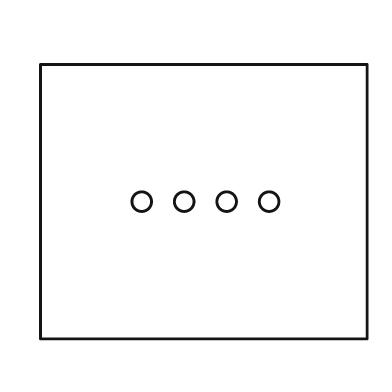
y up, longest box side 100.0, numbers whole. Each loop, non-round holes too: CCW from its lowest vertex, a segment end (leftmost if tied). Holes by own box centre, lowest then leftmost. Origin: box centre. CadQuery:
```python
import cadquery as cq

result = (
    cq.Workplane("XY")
    .moveTo(-50.0, -42.0)
    .lineTo(50.0, -42.0)
    .lineTo(50.0, 42.0)
    .lineTo(-50.0, 42.0)
    .close()
    .moveTo(-19.0, 0.0)
    .circle(3.0)
    .moveTo(-6.0, 0.0)
    .circle(3.0)
    .moveTo(7.0, 0.0)
    .circle(3.0)
    .moveTo(20.0, 0.0)
    .circle(3.0)
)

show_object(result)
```